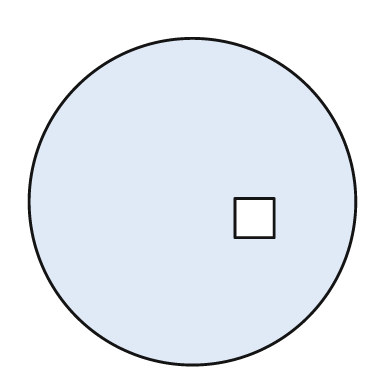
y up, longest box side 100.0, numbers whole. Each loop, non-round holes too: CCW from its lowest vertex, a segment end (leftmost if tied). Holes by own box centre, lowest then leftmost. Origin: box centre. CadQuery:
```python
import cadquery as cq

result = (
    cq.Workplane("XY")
    .moveTo(0.0, 0.0)
    .circle(50.0)
    .moveTo(13.0, -11.0)
    .lineTo(25.0, -11.0)
    .lineTo(25.0, 1.0)
    .lineTo(13.0, 1.0)
    .close()
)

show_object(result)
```